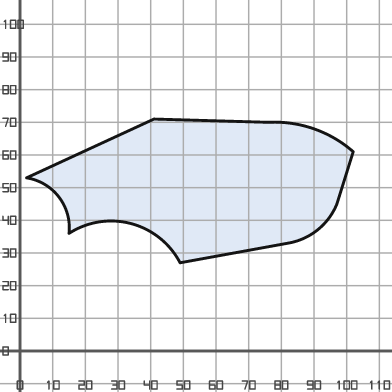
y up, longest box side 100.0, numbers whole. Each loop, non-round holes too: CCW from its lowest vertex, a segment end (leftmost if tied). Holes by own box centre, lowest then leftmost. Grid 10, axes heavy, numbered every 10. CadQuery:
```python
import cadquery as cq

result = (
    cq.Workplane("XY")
    .moveTo(49.0, 27.0)
    .lineTo(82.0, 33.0)
    .threePointArc((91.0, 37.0), (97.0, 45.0))
    .lineTo(102.0, 61.0)
    .threePointArc((90.0, 68.0), (76.0, 70.0))
    .lineTo(41.0, 71.0)
    .lineTo(2.0, 53.0)
    .threePointArc((12.0, 47.0), (15.0, 36.0))
    .threePointArc((34.0, 39.0), (49.0, 27.0))
    .close()
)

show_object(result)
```